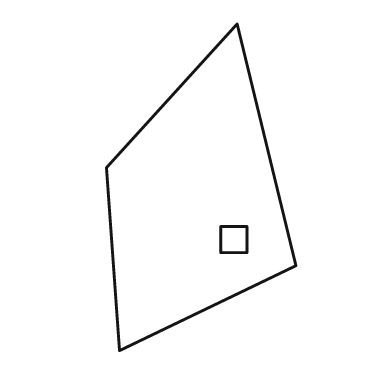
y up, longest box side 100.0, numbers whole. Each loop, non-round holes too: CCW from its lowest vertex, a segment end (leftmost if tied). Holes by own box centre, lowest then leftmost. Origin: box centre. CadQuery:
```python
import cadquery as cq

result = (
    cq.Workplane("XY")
    .moveTo(-25.0, -50.0)
    .lineTo(29.0, -24.0)
    .lineTo(11.0, 50.0)
    .lineTo(-29.0, 6.0)
    .close()
    .moveTo(6.0, -20.0)
    .lineTo(14.0, -20.0)
    .lineTo(14.0, -12.0)
    .lineTo(6.0, -12.0)
    .close()
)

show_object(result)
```